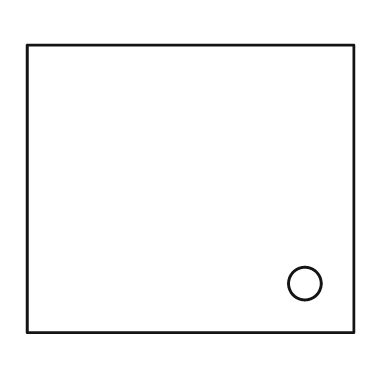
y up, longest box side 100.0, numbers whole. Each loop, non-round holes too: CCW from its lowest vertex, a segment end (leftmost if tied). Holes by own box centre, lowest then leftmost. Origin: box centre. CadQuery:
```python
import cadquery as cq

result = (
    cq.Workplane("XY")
    .moveTo(-50.0, -44.0)
    .lineTo(50.0, -44.0)
    .lineTo(50.0, 44.0)
    .lineTo(-50.0, 44.0)
    .close()
    .moveTo(35.0, -29.0)
    .circle(5.0)
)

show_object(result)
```